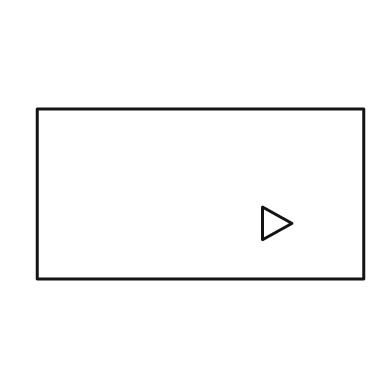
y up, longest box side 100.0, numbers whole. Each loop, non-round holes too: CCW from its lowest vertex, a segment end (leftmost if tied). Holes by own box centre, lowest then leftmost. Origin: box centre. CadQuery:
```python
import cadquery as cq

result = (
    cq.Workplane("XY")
    .moveTo(-50.0, -26.0)
    .lineTo(50.0, -26.0)
    .lineTo(50.0, 26.0)
    .lineTo(-50.0, 26.0)
    .close()
    .moveTo(19.0, -14.0)
    .lineTo(28.0, -9.0)
    .lineTo(19.0, -4.0)
    .close()
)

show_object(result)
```